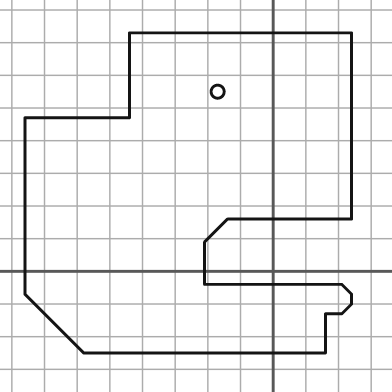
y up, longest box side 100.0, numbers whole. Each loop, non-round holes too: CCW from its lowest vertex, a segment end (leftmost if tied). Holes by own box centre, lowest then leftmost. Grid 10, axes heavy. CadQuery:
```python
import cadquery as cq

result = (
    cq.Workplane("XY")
    .moveTo(-58.0, -25.0)
    .lineTo(16.0, -25.0)
    .lineTo(16.0, -13.0)
    .lineTo(21.0, -13.0)
    .lineTo(24.0, -10.0)
    .lineTo(24.0, -7.0)
    .lineTo(21.0, -4.0)
    .lineTo(-21.0, -4.0)
    .lineTo(-21.0, 9.0)
    .lineTo(-14.0, 16.0)
    .lineTo(24.0, 16.0)
    .lineTo(24.0, 73.0)
    .lineTo(-44.0, 73.0)
    .lineTo(-44.0, 47.0)
    .lineTo(-76.0, 47.0)
    .lineTo(-76.0, -7.0)
    .close()
    .moveTo(-17.0, 55.0)
    .circle(2.0)
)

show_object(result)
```